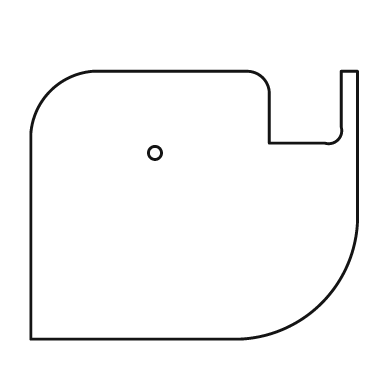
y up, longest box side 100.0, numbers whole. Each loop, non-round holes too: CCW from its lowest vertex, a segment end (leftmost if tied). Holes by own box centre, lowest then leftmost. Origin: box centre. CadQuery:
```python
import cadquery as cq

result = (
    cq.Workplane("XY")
    .moveTo(-50.0, -41.0)
    .lineTo(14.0, -41.0)
    .threePointArc((39.0, -30.0), (50.0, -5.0))
    .lineTo(50.0, 41.0)
    .lineTo(45.0, 41.0)
    .lineTo(45.0, 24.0)
    .threePointArc((44.0, 20.0), (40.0, 19.0))
    .lineTo(23.0, 19.0)
    .lineTo(23.0, 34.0)
    .threePointArc((21.0, 39.0), (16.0, 41.0))
    .lineTo(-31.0, 41.0)
    .threePointArc((-44.0, 35.0), (-50.0, 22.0))
    .close()
    .moveTo(-12.0, 16.0)
    .circle(2.0)
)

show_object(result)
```